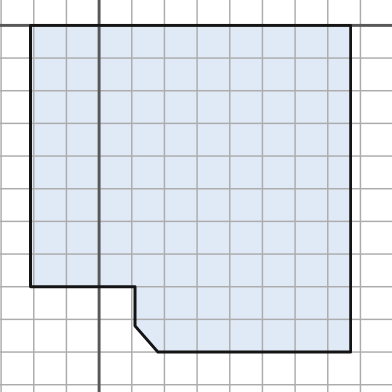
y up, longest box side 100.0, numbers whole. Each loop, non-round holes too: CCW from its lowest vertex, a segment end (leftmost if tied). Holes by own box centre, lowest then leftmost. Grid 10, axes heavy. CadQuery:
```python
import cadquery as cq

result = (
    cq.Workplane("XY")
    .moveTo(18.0, -100.0)
    .lineTo(77.0, -100.0)
    .lineTo(77.0, 0.0)
    .lineTo(-21.0, 0.0)
    .lineTo(-21.0, -80.0)
    .lineTo(11.0, -80.0)
    .lineTo(11.0, -92.0)
    .close()
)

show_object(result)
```